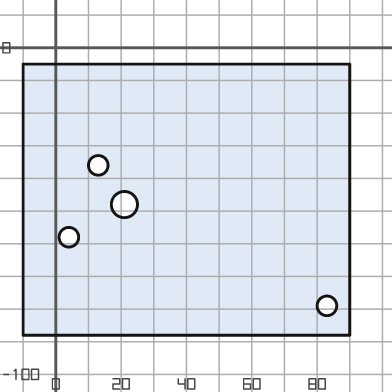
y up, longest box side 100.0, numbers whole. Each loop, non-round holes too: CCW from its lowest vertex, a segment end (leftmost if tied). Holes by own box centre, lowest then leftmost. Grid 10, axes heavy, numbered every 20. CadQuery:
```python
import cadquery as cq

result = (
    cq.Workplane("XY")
    .moveTo(-10.0, -88.0)
    .lineTo(90.0, -88.0)
    .lineTo(90.0, -5.0)
    .lineTo(-10.0, -5.0)
    .close()
    .moveTo(83.0, -79.0)
    .circle(3.0)
    .moveTo(4.0, -58.0)
    .circle(3.0)
    .moveTo(21.0, -48.0)
    .circle(4.0)
    .moveTo(13.0, -36.0)
    .circle(3.0)
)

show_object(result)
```